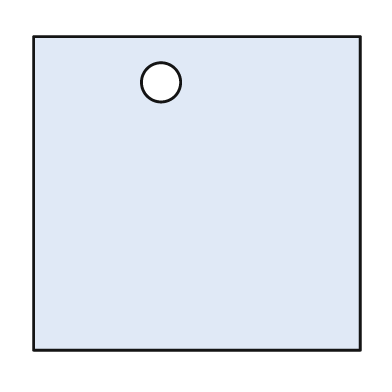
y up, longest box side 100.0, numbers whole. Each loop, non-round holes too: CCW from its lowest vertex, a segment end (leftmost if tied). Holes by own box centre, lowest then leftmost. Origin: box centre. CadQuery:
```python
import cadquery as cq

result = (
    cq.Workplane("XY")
    .moveTo(-50.0, -48.0)
    .lineTo(50.0, -48.0)
    .lineTo(50.0, 48.0)
    .lineTo(-50.0, 48.0)
    .close()
    .moveTo(-11.0, 34.0)
    .circle(6.0)
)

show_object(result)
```